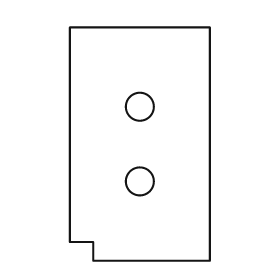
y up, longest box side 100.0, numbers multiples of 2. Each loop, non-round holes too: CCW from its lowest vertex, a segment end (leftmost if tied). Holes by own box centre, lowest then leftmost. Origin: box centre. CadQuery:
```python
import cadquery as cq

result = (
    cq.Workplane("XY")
    .moveTo(-20.0, -50.0)
    .lineTo(30.0, -50.0)
    .lineTo(30.0, 50.0)
    .lineTo(-30.0, 50.0)
    .lineTo(-30.0, -42.0)
    .lineTo(-20.0, -42.0)
    .close()
    .moveTo(0.0, -16.0)
    .circle(6.0)
    .moveTo(0.0, 16.0)
    .circle(6.0)
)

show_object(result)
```